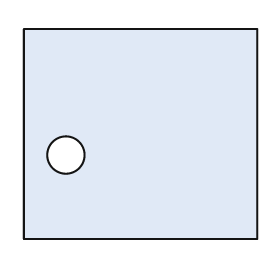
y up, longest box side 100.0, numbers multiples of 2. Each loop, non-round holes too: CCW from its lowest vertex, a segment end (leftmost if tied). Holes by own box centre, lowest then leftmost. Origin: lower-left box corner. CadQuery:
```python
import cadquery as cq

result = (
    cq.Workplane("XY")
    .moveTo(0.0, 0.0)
    .lineTo(100.0, 0.0)
    .lineTo(100.0, 90.0)
    .lineTo(0.0, 90.0)
    .close()
    .moveTo(18.0, 36.0)
    .circle(8.0)
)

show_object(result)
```